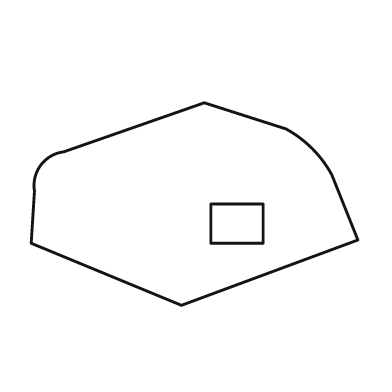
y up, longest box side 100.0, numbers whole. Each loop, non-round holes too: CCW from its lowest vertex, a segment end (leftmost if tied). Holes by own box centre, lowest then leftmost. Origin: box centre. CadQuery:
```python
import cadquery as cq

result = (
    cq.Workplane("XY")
    .moveTo(-4.0, -31.0)
    .lineTo(50.0, -11.0)
    .lineTo(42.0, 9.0)
    .threePointArc((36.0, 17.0), (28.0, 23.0))
    .lineTo(3.0, 31.0)
    .lineTo(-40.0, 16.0)
    .threePointArc((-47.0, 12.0), (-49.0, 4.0))
    .lineTo(-50.0, -12.0)
    .close()
    .moveTo(5.0, -12.0)
    .lineTo(21.0, -12.0)
    .lineTo(21.0, 0.0)
    .lineTo(5.0, 0.0)
    .close()
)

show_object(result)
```